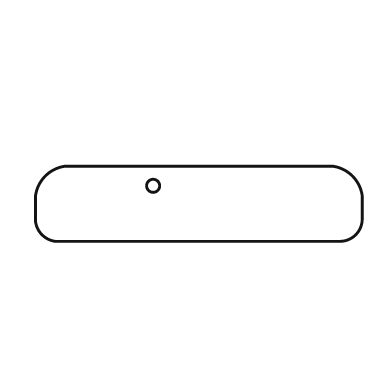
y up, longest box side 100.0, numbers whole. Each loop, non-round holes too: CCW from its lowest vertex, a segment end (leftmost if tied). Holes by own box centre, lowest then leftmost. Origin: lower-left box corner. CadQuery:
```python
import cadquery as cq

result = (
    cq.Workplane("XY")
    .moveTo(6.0, 0.0)
    .lineTo(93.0, 0.0)
    .threePointArc((98.0, 2.0), (100.0, 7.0))
    .lineTo(100.0, 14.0)
    .threePointArc((97.0, 20.0), (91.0, 23.0))
    .lineTo(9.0, 23.0)
    .threePointArc((3.0, 20.0), (0.0, 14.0))
    .lineTo(0.0, 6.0)
    .threePointArc((2.0, 2.0), (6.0, 0.0))
    .close()
    .moveTo(36.0, 17.0)
    .circle(2.0)
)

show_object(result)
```